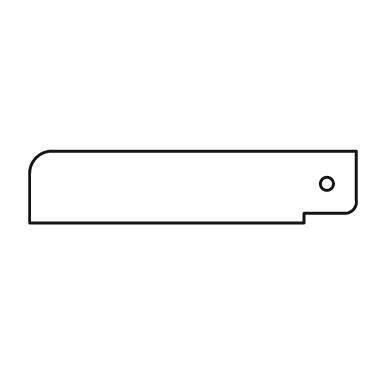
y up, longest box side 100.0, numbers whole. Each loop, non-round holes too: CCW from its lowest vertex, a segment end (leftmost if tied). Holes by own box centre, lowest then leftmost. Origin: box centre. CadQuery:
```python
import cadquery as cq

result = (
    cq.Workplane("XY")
    .moveTo(-50.0, -11.0)
    .lineTo(34.0, -11.0)
    .lineTo(34.0, -8.0)
    .lineTo(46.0, -8.0)
    .threePointArc((49.0, -7.0), (50.0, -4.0))
    .lineTo(50.0, 11.0)
    .lineTo(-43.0, 11.0)
    .threePointArc((-48.0, 9.0), (-50.0, 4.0))
    .close()
    .moveTo(41.0, 1.0)
    .circle(2.0)
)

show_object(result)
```